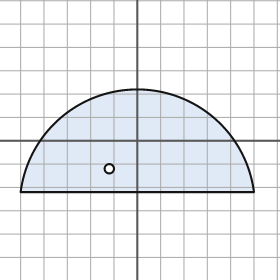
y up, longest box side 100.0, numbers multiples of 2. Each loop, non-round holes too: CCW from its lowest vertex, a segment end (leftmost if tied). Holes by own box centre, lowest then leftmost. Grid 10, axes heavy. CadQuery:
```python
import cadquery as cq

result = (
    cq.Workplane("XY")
    .moveTo(-50.0, -22.0)
    .lineTo(50.0, -22.0)
    .threePointArc((0.0, 22.0), (-50.0, -22.0))
    .close()
    .moveTo(-12.0, -12.0)
    .circle(2.0)
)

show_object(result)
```